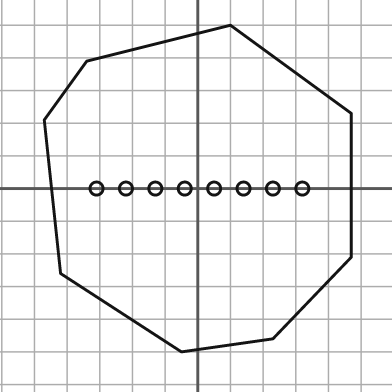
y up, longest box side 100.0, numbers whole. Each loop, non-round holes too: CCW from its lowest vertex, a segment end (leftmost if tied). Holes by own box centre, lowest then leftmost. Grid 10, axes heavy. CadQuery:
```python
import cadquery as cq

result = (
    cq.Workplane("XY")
    .moveTo(-5.0, -50.0)
    .lineTo(23.0, -46.0)
    .lineTo(47.0, -21.0)
    .lineTo(47.0, 23.0)
    .lineTo(10.0, 50.0)
    .lineTo(-34.0, 39.0)
    .lineTo(-47.0, 21.0)
    .lineTo(-42.0, -26.0)
    .close()
    .moveTo(-31.0, 0.0)
    .circle(2.0)
    .moveTo(-22.0, 0.0)
    .circle(2.0)
    .moveTo(-13.0, 0.0)
    .circle(2.0)
    .moveTo(-4.0, 0.0)
    .circle(2.0)
    .moveTo(5.0, 0.0)
    .circle(2.0)
    .moveTo(14.0, 0.0)
    .circle(2.0)
    .moveTo(23.0, 0.0)
    .circle(2.0)
    .moveTo(32.0, 0.0)
    .circle(2.0)
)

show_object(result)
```